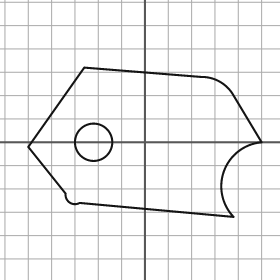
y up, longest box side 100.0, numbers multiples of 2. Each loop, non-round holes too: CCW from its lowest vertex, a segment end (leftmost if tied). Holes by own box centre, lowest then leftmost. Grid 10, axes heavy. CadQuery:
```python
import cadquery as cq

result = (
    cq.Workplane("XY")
    .moveTo(38.0, -32.0)
    .threePointArc((34.0, -12.0), (50.0, 0.0))
    .lineTo(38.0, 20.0)
    .threePointArc((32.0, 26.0), (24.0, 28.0))
    .lineTo(-26.0, 32.0)
    .lineTo(-50.0, -2.0)
    .lineTo(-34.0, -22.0)
    .threePointArc((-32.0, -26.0), (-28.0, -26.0))
    .close()
    .moveTo(-22.0, 0.0)
    .circle(8.0)
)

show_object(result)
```